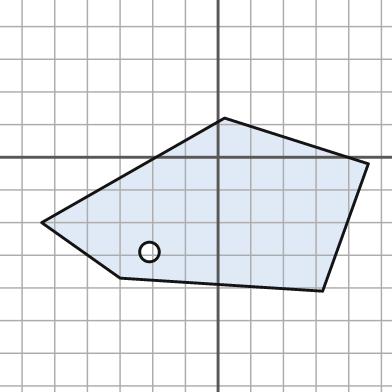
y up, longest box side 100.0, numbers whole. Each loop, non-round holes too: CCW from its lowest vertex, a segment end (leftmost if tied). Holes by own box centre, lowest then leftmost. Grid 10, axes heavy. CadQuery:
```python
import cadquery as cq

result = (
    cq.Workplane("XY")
    .moveTo(32.0, -41.0)
    .lineTo(46.0, -2.0)
    .lineTo(2.0, 12.0)
    .lineTo(-54.0, -20.0)
    .lineTo(-30.0, -37.0)
    .close()
    .moveTo(-21.0, -29.0)
    .circle(3.0)
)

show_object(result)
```